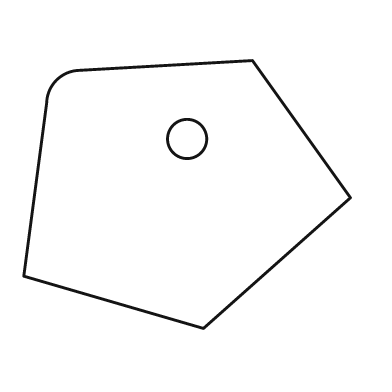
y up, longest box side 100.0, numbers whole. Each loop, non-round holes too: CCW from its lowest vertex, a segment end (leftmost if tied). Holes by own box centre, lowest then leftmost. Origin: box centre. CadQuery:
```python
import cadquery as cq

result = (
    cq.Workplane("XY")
    .moveTo(5.0, -41.0)
    .lineTo(50.0, -1.0)
    .lineTo(20.0, 41.0)
    .lineTo(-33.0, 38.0)
    .threePointArc((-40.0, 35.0), (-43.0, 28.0))
    .lineTo(-50.0, -25.0)
    .close()
    .moveTo(0.0, 17.0)
    .circle(6.0)
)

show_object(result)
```